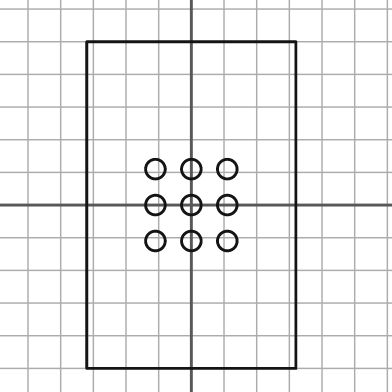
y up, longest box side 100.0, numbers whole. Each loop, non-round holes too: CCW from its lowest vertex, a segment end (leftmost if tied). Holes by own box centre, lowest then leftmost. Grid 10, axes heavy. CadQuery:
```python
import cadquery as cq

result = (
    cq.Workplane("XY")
    .moveTo(-32.0, -50.0)
    .lineTo(32.0, -50.0)
    .lineTo(32.0, 50.0)
    .lineTo(-32.0, 50.0)
    .close()
    .moveTo(-11.0, -11.0)
    .circle(3.0)
    .moveTo(0.0, -11.0)
    .circle(3.0)
    .moveTo(11.0, -11.0)
    .circle(3.0)
    .moveTo(-11.0, 0.0)
    .circle(3.0)
    .moveTo(0.0, 0.0)
    .circle(3.0)
    .moveTo(11.0, 0.0)
    .circle(3.0)
    .moveTo(-11.0, 11.0)
    .circle(3.0)
    .moveTo(0.0, 11.0)
    .circle(3.0)
    .moveTo(11.0, 11.0)
    .circle(3.0)
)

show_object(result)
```